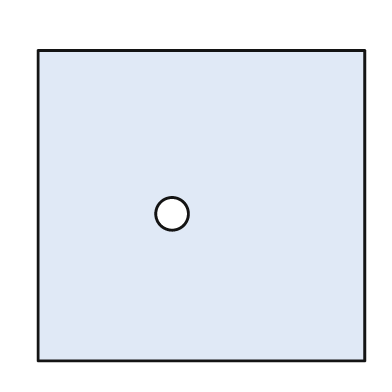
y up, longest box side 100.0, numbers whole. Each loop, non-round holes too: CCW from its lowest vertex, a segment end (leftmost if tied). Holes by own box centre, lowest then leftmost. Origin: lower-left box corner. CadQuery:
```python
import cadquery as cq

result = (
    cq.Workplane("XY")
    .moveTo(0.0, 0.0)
    .lineTo(100.0, 0.0)
    .lineTo(100.0, 95.0)
    .lineTo(0.0, 95.0)
    .close()
    .moveTo(41.0, 45.0)
    .circle(5.0)
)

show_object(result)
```